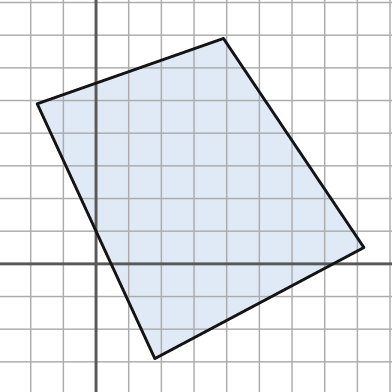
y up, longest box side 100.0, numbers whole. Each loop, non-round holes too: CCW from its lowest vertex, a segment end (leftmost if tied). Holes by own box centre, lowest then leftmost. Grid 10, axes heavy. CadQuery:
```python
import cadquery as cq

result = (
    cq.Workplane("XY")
    .moveTo(18.0, -29.0)
    .lineTo(82.0, 5.0)
    .lineTo(39.0, 69.0)
    .lineTo(-18.0, 49.0)
    .close()
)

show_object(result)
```